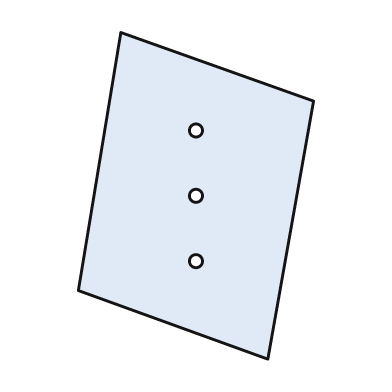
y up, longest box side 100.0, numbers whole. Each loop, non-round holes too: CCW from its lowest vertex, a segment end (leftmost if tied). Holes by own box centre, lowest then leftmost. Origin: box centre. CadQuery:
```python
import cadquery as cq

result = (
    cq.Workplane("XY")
    .moveTo(22.0, -50.0)
    .lineTo(36.0, 29.0)
    .lineTo(-23.0, 50.0)
    .lineTo(-36.0, -29.0)
    .close()
    .moveTo(0.0, -20.0)
    .circle(2.0)
    .moveTo(0.0, 0.0)
    .circle(2.0)
    .moveTo(0.0, 20.0)
    .circle(2.0)
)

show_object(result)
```